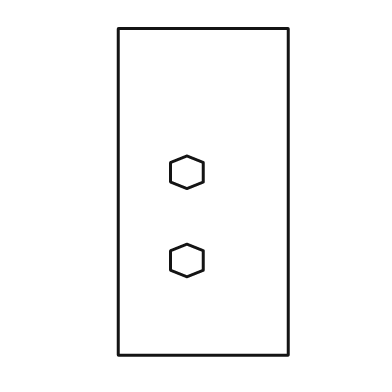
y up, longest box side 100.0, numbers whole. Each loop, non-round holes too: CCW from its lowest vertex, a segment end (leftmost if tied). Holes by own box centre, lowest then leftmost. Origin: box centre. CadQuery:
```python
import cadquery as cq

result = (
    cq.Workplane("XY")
    .moveTo(-26.0, -50.0)
    .lineTo(26.0, -50.0)
    .lineTo(26.0, 50.0)
    .lineTo(-26.0, 50.0)
    .close()
    .moveTo(-5.0, -26.0)
    .lineTo(0.0, -24.0)
    .lineTo(0.0, -18.0)
    .lineTo(-5.0, -16.0)
    .lineTo(-10.0, -18.0)
    .lineTo(-10.0, -24.0)
    .close()
    .moveTo(-5.0, 1.0)
    .lineTo(0.0, 3.0)
    .lineTo(0.0, 9.0)
    .lineTo(-5.0, 11.0)
    .lineTo(-10.0, 9.0)
    .lineTo(-10.0, 3.0)
    .close()
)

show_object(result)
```